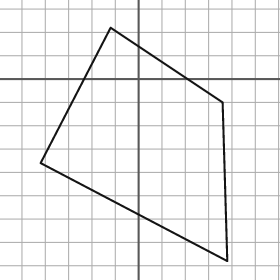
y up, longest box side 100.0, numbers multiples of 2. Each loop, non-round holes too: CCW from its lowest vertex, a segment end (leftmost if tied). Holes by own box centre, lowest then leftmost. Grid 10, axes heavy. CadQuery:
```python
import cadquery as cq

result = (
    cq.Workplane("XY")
    .moveTo(38.0, -78.0)
    .lineTo(36.0, -10.0)
    .lineTo(-12.0, 22.0)
    .lineTo(-42.0, -36.0)
    .close()
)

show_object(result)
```